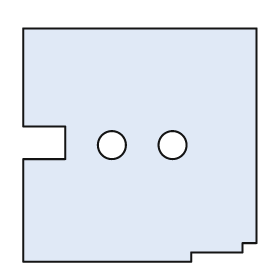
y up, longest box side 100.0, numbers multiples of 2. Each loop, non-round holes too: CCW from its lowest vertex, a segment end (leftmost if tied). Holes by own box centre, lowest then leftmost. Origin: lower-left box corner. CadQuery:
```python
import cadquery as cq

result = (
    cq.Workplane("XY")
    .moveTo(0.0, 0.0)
    .lineTo(72.0, 0.0)
    .lineTo(72.0, 4.0)
    .lineTo(94.0, 4.0)
    .lineTo(94.0, 8.0)
    .lineTo(100.0, 8.0)
    .lineTo(100.0, 100.0)
    .lineTo(0.0, 100.0)
    .lineTo(0.0, 58.0)
    .lineTo(18.0, 58.0)
    .lineTo(18.0, 44.0)
    .lineTo(0.0, 44.0)
    .close()
    .moveTo(38.0, 50.0)
    .circle(6.0)
    .moveTo(64.0, 50.0)
    .circle(6.0)
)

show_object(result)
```